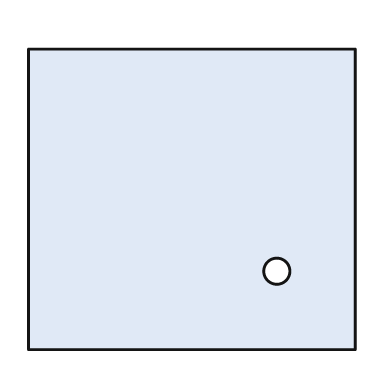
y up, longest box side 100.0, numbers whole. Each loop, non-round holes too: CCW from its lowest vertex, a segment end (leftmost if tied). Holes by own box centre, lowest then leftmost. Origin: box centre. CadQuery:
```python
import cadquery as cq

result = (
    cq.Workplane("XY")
    .moveTo(-50.0, -46.0)
    .lineTo(50.0, -46.0)
    .lineTo(50.0, 46.0)
    .lineTo(-50.0, 46.0)
    .close()
    .moveTo(26.0, -22.0)
    .circle(4.0)
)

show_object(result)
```